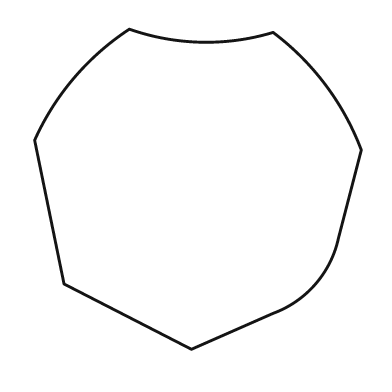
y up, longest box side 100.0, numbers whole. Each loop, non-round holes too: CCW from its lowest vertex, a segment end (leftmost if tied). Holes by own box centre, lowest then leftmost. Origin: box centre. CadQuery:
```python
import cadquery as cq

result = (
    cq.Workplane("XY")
    .moveTo(-2.0, -49.0)
    .lineTo(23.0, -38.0)
    .threePointArc((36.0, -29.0), (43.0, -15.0))
    .lineTo(50.0, 12.0)
    .threePointArc((39.0, 32.0), (23.0, 48.0))
    .threePointArc((1.0, 45.0), (-21.0, 49.0))
    .threePointArc((-38.0, 34.0), (-50.0, 15.0))
    .lineTo(-41.0, -29.0)
    .close()
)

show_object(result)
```